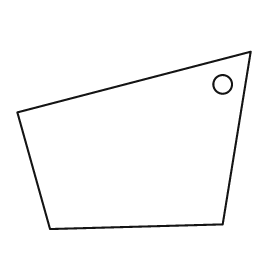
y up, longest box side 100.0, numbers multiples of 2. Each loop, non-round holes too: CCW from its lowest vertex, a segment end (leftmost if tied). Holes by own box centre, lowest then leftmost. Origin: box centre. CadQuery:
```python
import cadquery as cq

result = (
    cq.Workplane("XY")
    .moveTo(-36.0, -38.0)
    .lineTo(38.0, -36.0)
    .lineTo(50.0, 38.0)
    .lineTo(-50.0, 12.0)
    .close()
    .moveTo(38.0, 24.0)
    .circle(4.0)
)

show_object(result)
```